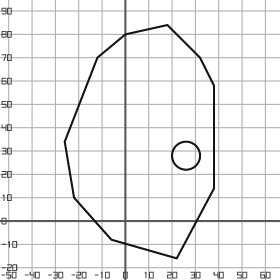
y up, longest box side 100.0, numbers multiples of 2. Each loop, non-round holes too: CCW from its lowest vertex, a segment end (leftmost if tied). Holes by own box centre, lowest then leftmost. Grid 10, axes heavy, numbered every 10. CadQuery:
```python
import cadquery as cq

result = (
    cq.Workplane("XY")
    .moveTo(22.0, -16.0)
    .lineTo(38.0, 14.0)
    .lineTo(38.0, 58.0)
    .lineTo(32.0, 70.0)
    .lineTo(18.0, 84.0)
    .lineTo(0.0, 80.0)
    .lineTo(-12.0, 70.0)
    .lineTo(-26.0, 34.0)
    .lineTo(-22.0, 10.0)
    .lineTo(-6.0, -8.0)
    .close()
    .moveTo(26.0, 28.0)
    .circle(6.0)
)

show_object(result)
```